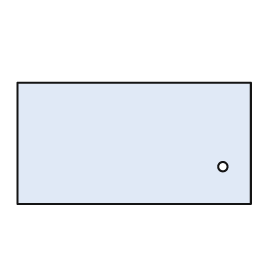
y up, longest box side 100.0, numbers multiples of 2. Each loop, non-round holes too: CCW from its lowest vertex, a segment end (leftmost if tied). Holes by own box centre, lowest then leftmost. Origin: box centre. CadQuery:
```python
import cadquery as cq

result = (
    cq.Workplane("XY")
    .moveTo(-50.0, -26.0)
    .lineTo(50.0, -26.0)
    .lineTo(50.0, 26.0)
    .lineTo(-50.0, 26.0)
    .close()
    .moveTo(38.0, -10.0)
    .circle(2.0)
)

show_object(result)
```